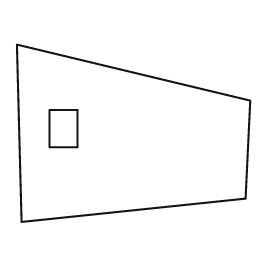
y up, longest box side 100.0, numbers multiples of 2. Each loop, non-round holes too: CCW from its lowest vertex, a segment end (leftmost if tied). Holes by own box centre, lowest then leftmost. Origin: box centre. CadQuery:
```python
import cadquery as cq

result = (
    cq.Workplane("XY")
    .moveTo(-48.0, -38.0)
    .lineTo(48.0, -28.0)
    .lineTo(50.0, 14.0)
    .lineTo(-50.0, 38.0)
    .close()
    .moveTo(-36.0, -6.0)
    .lineTo(-24.0, -6.0)
    .lineTo(-24.0, 10.0)
    .lineTo(-36.0, 10.0)
    .close()
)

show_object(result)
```